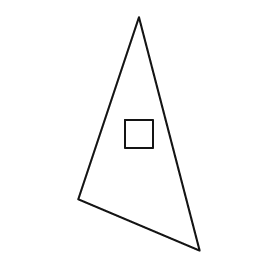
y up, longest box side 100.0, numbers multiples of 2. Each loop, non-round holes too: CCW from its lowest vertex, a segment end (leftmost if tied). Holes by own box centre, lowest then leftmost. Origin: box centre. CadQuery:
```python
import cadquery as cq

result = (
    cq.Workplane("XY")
    .moveTo(26.0, -50.0)
    .lineTo(0.0, 50.0)
    .lineTo(-26.0, -28.0)
    .close()
    .moveTo(-6.0, -6.0)
    .lineTo(6.0, -6.0)
    .lineTo(6.0, 6.0)
    .lineTo(-6.0, 6.0)
    .close()
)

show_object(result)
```